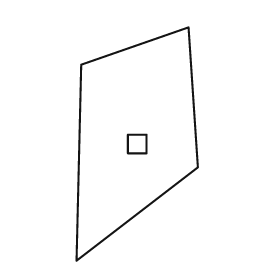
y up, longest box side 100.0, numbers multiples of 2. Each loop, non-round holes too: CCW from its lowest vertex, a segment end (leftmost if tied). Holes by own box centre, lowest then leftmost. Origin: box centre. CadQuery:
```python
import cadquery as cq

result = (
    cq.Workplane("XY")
    .moveTo(-26.0, -50.0)
    .lineTo(26.0, -10.0)
    .lineTo(22.0, 50.0)
    .lineTo(-24.0, 34.0)
    .close()
    .moveTo(-4.0, -4.0)
    .lineTo(4.0, -4.0)
    .lineTo(4.0, 4.0)
    .lineTo(-4.0, 4.0)
    .close()
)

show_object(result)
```